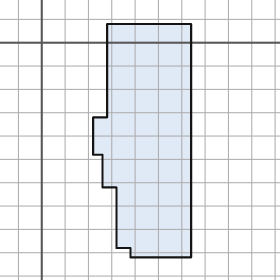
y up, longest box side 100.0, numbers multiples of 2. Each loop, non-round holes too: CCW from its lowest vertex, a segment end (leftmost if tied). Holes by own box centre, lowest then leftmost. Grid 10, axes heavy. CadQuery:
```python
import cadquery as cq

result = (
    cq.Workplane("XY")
    .moveTo(38.0, -92.0)
    .lineTo(64.0, -92.0)
    .lineTo(64.0, 8.0)
    .lineTo(28.0, 8.0)
    .lineTo(28.0, -32.0)
    .lineTo(22.0, -32.0)
    .lineTo(22.0, -48.0)
    .lineTo(26.0, -48.0)
    .lineTo(26.0, -62.0)
    .lineTo(32.0, -62.0)
    .lineTo(32.0, -88.0)
    .lineTo(38.0, -88.0)
    .close()
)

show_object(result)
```